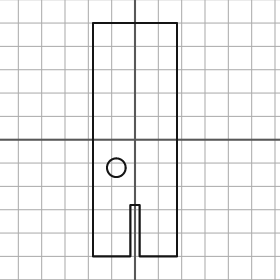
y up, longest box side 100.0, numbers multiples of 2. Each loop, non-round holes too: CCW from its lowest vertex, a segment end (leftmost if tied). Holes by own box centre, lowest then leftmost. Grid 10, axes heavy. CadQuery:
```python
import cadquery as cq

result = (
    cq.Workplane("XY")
    .moveTo(-18.0, -50.0)
    .lineTo(-2.0, -50.0)
    .lineTo(-2.0, -28.0)
    .lineTo(2.0, -28.0)
    .lineTo(2.0, -50.0)
    .lineTo(18.0, -50.0)
    .lineTo(18.0, 50.0)
    .lineTo(-18.0, 50.0)
    .close()
    .moveTo(-8.0, -12.0)
    .circle(4.0)
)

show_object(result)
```